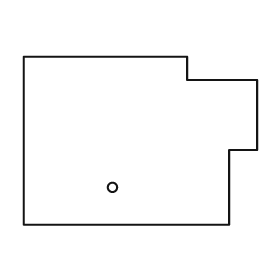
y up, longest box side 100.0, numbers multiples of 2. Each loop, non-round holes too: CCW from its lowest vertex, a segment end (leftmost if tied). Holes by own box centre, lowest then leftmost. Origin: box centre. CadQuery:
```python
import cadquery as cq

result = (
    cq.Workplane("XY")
    .moveTo(-50.0, -36.0)
    .lineTo(38.0, -36.0)
    .lineTo(38.0, -4.0)
    .lineTo(50.0, -4.0)
    .lineTo(50.0, 26.0)
    .lineTo(20.0, 26.0)
    .lineTo(20.0, 36.0)
    .lineTo(-50.0, 36.0)
    .close()
    .moveTo(-12.0, -20.0)
    .circle(2.0)
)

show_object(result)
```